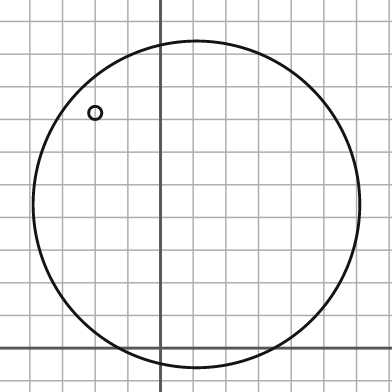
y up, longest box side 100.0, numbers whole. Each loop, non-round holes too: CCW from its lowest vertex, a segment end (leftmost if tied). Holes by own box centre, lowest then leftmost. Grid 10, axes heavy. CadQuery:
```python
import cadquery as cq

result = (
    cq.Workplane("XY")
    .moveTo(11.0, 44.0)
    .circle(50.0)
    .moveTo(-20.0, 72.0)
    .circle(2.0)
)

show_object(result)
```